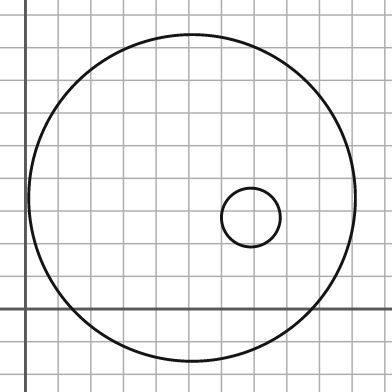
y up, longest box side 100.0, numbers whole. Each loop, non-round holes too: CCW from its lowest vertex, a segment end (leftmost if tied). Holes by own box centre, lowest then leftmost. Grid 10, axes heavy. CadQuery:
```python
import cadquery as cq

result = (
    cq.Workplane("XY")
    .moveTo(51.0, 34.0)
    .circle(50.0)
    .moveTo(69.0, 28.0)
    .circle(9.0)
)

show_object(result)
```